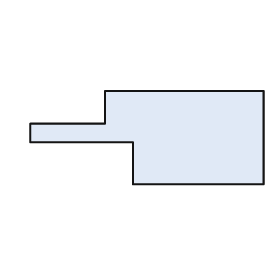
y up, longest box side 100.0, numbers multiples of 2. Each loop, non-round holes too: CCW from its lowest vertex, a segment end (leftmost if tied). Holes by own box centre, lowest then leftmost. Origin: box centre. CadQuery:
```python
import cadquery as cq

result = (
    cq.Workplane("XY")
    .moveTo(-6.0, -20.0)
    .lineTo(50.0, -20.0)
    .lineTo(50.0, 20.0)
    .lineTo(-18.0, 20.0)
    .lineTo(-18.0, 6.0)
    .lineTo(-50.0, 6.0)
    .lineTo(-50.0, -2.0)
    .lineTo(-6.0, -2.0)
    .close()
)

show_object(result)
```